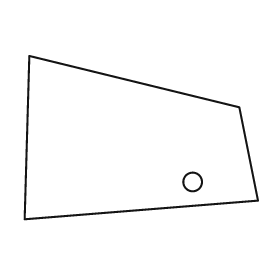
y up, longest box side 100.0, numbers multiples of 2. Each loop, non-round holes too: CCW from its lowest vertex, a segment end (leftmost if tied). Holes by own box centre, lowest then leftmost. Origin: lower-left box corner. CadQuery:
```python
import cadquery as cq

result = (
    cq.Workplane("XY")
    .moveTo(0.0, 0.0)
    .lineTo(100.0, 8.0)
    .lineTo(92.0, 48.0)
    .lineTo(2.0, 70.0)
    .close()
    .moveTo(72.0, 16.0)
    .circle(4.0)
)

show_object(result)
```